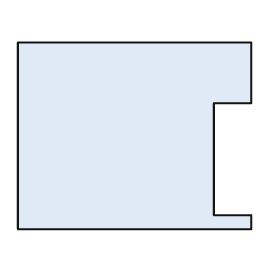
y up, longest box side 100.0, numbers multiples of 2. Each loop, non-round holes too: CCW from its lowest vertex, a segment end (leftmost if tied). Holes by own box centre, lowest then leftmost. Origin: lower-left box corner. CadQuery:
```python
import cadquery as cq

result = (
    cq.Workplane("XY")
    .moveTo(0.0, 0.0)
    .lineTo(100.0, 0.0)
    .lineTo(100.0, 6.0)
    .lineTo(84.0, 6.0)
    .lineTo(84.0, 54.0)
    .lineTo(100.0, 54.0)
    .lineTo(100.0, 80.0)
    .lineTo(0.0, 80.0)
    .close()
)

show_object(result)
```